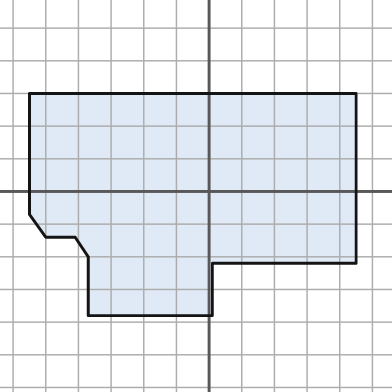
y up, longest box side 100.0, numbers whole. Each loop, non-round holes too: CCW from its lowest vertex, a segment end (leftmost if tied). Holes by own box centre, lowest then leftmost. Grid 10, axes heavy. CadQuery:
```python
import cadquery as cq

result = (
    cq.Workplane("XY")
    .moveTo(-37.0, -38.0)
    .lineTo(1.0, -38.0)
    .lineTo(1.0, -22.0)
    .lineTo(45.0, -22.0)
    .lineTo(45.0, 30.0)
    .lineTo(-55.0, 30.0)
    .lineTo(-55.0, -7.0)
    .lineTo(-50.0, -14.0)
    .lineTo(-41.0, -14.0)
    .lineTo(-37.0, -20.0)
    .close()
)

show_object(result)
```